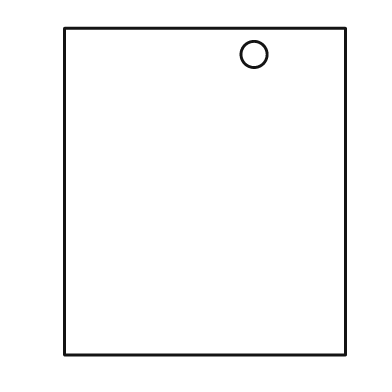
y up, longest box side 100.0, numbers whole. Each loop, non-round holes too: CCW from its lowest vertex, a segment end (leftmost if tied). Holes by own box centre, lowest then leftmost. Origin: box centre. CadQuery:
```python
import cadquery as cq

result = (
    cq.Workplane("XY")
    .moveTo(-43.0, -50.0)
    .lineTo(43.0, -50.0)
    .lineTo(43.0, 50.0)
    .lineTo(-43.0, 50.0)
    .close()
    .moveTo(15.0, 42.0)
    .circle(4.0)
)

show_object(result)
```